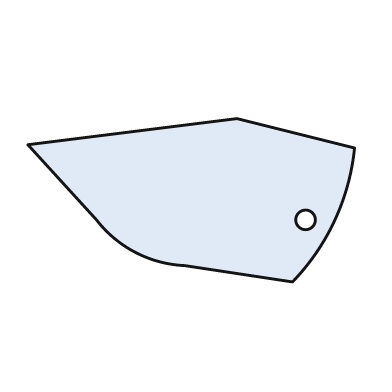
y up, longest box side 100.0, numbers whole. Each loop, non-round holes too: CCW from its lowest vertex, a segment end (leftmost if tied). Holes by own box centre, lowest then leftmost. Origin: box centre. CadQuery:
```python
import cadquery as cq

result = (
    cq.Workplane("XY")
    .moveTo(31.0, -25.0)
    .threePointArc((44.0, -6.0), (50.0, 16.0))
    .lineTo(14.0, 25.0)
    .lineTo(-50.0, 17.0)
    .lineTo(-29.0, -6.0)
    .threePointArc((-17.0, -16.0), (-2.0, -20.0))
    .close()
    .moveTo(35.0, -6.0)
    .circle(3.0)
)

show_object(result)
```